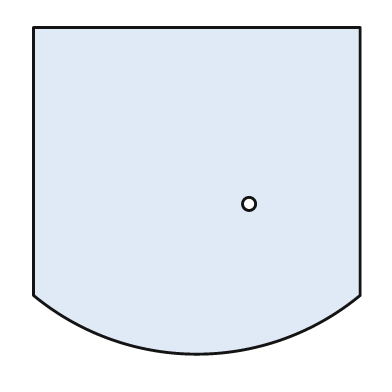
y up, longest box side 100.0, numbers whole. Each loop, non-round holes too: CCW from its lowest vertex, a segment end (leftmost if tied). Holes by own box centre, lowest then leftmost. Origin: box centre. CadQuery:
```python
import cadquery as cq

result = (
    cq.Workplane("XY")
    .moveTo(-50.0, -32.0)
    .threePointArc((0.0, -50.0), (50.0, -32.0))
    .lineTo(50.0, 50.0)
    .lineTo(-50.0, 50.0)
    .close()
    .moveTo(16.0, -4.0)
    .circle(2.0)
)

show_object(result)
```